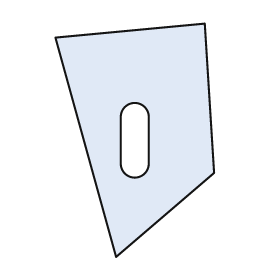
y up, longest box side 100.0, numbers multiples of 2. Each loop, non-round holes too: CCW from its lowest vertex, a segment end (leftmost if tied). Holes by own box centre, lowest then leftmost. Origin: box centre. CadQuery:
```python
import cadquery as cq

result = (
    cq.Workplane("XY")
    .moveTo(-8.0, -50.0)
    .lineTo(34.0, -14.0)
    .lineTo(30.0, 50.0)
    .lineTo(-34.0, 44.0)
    .close()
    .moveTo(-6.0, -10.0)
    .threePointArc((0.0, -16.0), (6.0, -10.0))
    .lineTo(6.0, 10.0)
    .threePointArc((0.0, 16.0), (-6.0, 10.0))
    .close()
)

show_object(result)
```